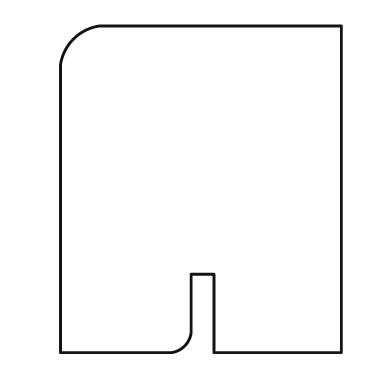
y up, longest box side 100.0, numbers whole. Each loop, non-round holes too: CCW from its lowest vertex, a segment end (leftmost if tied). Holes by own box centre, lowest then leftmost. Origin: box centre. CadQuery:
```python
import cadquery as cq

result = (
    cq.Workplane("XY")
    .moveTo(-43.0, -50.0)
    .lineTo(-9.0, -50.0)
    .threePointArc((-5.0, -48.0), (-3.0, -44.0))
    .lineTo(-3.0, -26.0)
    .lineTo(4.0, -26.0)
    .lineTo(4.0, -50.0)
    .lineTo(43.0, -50.0)
    .lineTo(43.0, 50.0)
    .lineTo(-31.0, 50.0)
    .threePointArc((-39.0, 46.0), (-43.0, 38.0))
    .close()
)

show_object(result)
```